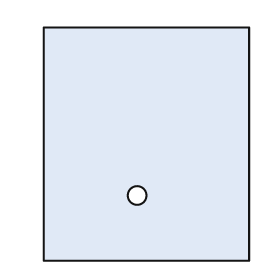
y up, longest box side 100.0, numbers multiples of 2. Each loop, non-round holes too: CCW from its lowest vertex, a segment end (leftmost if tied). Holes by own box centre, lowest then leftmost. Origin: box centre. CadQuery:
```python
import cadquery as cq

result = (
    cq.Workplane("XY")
    .moveTo(-44.0, -50.0)
    .lineTo(44.0, -50.0)
    .lineTo(44.0, 50.0)
    .lineTo(-44.0, 50.0)
    .close()
    .moveTo(-4.0, -22.0)
    .circle(4.0)
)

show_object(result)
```